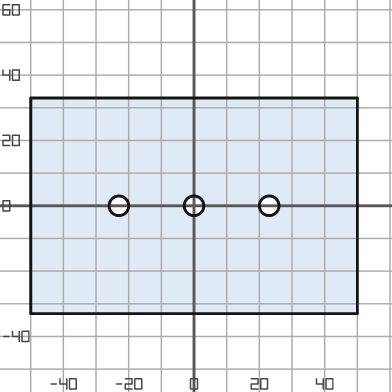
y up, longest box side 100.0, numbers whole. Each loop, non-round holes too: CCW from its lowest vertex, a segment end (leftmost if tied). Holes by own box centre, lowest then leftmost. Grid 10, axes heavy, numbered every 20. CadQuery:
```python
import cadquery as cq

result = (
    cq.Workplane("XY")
    .moveTo(-50.0, -33.0)
    .lineTo(50.0, -33.0)
    .lineTo(50.0, 33.0)
    .lineTo(-50.0, 33.0)
    .close()
    .moveTo(-23.0, 0.0)
    .circle(3.0)
    .moveTo(0.0, 0.0)
    .circle(3.0)
    .moveTo(23.0, 0.0)
    .circle(3.0)
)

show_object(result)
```